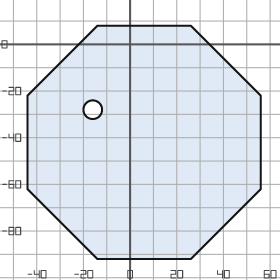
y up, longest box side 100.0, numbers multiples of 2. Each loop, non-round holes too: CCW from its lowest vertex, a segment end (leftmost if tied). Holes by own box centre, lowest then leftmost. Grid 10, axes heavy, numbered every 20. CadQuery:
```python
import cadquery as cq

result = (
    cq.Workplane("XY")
    .moveTo(-14.0, -92.0)
    .lineTo(26.0, -92.0)
    .lineTo(56.0, -62.0)
    .lineTo(56.0, -22.0)
    .lineTo(26.0, 8.0)
    .lineTo(-14.0, 8.0)
    .lineTo(-44.0, -22.0)
    .lineTo(-44.0, -62.0)
    .close()
    .moveTo(-16.0, -28.0)
    .circle(4.0)
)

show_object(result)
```